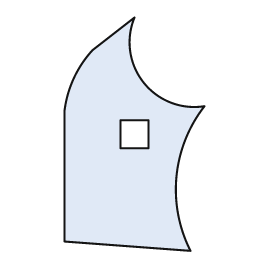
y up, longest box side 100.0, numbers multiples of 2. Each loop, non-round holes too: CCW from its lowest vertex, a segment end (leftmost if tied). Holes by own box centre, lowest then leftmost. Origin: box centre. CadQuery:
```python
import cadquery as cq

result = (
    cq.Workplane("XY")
    .moveTo(24.0, -50.0)
    .threePointArc((18.0, -18.0), (30.0, 12.0))
    .threePointArc((4.0, 22.0), (0.0, 50.0))
    .lineTo(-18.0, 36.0)
    .threePointArc((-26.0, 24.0), (-30.0, 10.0))
    .lineTo(-30.0, -46.0)
    .close()
    .moveTo(-6.0, -6.0)
    .lineTo(6.0, -6.0)
    .lineTo(6.0, 6.0)
    .lineTo(-6.0, 6.0)
    .close()
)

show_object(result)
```